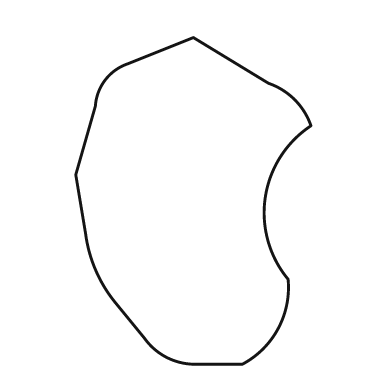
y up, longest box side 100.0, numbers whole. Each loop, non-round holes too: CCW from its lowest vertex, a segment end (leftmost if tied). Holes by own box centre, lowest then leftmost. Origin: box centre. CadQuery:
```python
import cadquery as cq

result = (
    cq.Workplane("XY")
    .moveTo(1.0, -50.0)
    .lineTo(15.0, -50.0)
    .threePointArc((26.0, -39.0), (29.0, -24.0))
    .threePointArc((22.0, 1.0), (36.0, 23.0))
    .threePointArc((31.0, 31.0), (23.0, 36.0))
    .lineTo(0.0, 50.0)
    .lineTo(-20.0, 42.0)
    .threePointArc((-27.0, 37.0), (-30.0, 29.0))
    .lineTo(-36.0, 8.0)
    .lineTo(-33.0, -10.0)
    .threePointArc((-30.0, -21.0), (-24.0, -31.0))
    .lineTo(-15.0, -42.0)
    .threePointArc((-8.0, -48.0), (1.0, -50.0))
    .close()
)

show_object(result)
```